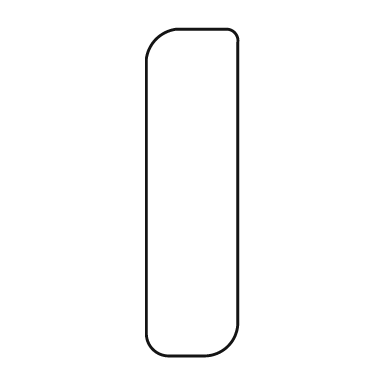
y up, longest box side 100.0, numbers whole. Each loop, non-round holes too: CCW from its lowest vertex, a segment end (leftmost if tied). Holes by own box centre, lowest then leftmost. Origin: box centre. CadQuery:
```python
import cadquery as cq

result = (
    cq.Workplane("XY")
    .moveTo(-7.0, -50.0)
    .lineTo(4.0, -50.0)
    .threePointArc((11.0, -47.0), (14.0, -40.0))
    .lineTo(14.0, 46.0)
    .threePointArc((13.0, 49.0), (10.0, 50.0))
    .lineTo(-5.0, 50.0)
    .threePointArc((-11.0, 47.0), (-14.0, 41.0))
    .lineTo(-14.0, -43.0)
    .threePointArc((-12.0, -48.0), (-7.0, -50.0))
    .close()
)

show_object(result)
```